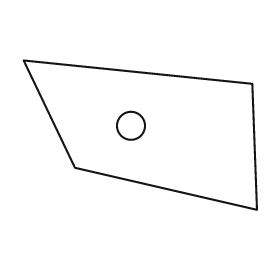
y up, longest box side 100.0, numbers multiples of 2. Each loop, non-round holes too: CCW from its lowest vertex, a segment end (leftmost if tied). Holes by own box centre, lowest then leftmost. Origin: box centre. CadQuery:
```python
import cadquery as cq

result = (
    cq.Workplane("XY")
    .moveTo(50.0, -32.0)
    .lineTo(48.0, 22.0)
    .lineTo(-50.0, 32.0)
    .lineTo(-28.0, -14.0)
    .close()
    .moveTo(-4.0, 4.0)
    .circle(6.0)
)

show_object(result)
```